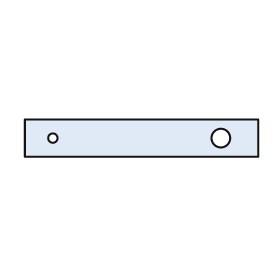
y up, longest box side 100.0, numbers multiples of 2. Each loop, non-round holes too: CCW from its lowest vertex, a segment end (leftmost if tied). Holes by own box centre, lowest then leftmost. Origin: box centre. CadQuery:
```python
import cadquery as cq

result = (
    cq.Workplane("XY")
    .moveTo(-50.0, -8.0)
    .lineTo(50.0, -8.0)
    .lineTo(50.0, 8.0)
    .lineTo(-50.0, 8.0)
    .close()
    .moveTo(-38.0, 0.0)
    .circle(2.0)
    .moveTo(34.0, 0.0)
    .circle(4.0)
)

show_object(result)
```